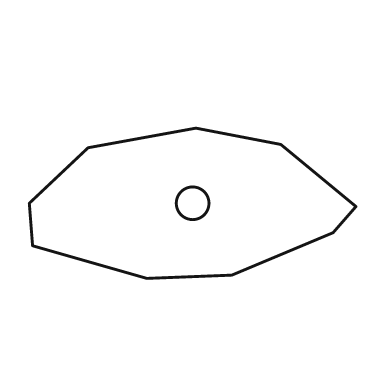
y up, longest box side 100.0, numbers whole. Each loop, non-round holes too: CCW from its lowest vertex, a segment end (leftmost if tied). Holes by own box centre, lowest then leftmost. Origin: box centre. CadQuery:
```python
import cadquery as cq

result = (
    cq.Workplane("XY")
    .moveTo(-14.0, -23.0)
    .lineTo(12.0, -22.0)
    .lineTo(43.0, -9.0)
    .lineTo(50.0, -1.0)
    .lineTo(27.0, 18.0)
    .lineTo(1.0, 23.0)
    .lineTo(-32.0, 17.0)
    .lineTo(-50.0, 0.0)
    .lineTo(-49.0, -13.0)
    .close()
    .moveTo(0.0, 0.0)
    .circle(5.0)
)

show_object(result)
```